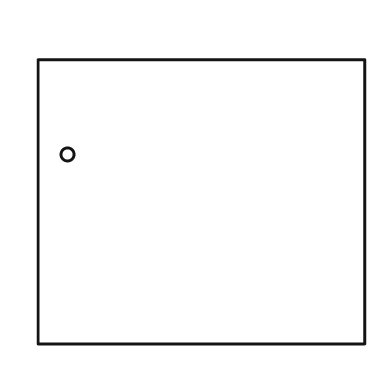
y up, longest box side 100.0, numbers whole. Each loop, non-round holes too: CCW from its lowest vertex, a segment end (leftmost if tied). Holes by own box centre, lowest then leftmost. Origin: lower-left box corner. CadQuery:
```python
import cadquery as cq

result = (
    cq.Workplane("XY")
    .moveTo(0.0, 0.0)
    .lineTo(100.0, 0.0)
    .lineTo(100.0, 87.0)
    .lineTo(0.0, 87.0)
    .close()
    .moveTo(9.0, 58.0)
    .circle(2.0)
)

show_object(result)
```